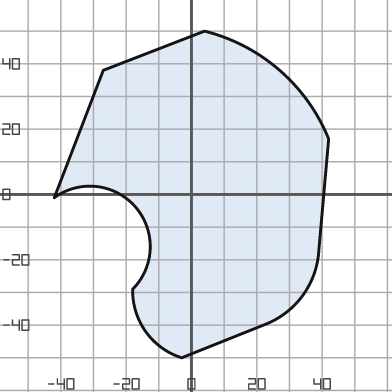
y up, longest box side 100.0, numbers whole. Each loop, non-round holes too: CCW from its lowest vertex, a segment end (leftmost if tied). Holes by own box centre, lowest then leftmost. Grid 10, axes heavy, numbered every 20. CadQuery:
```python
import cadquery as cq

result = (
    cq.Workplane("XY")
    .moveTo(-3.0, -50.0)
    .lineTo(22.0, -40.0)
    .threePointArc((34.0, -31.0), (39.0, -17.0))
    .lineTo(42.0, 17.0)
    .threePointArc((27.0, 38.0), (4.0, 50.0))
    .lineTo(-27.0, 38.0)
    .lineTo(-42.0, -1.0)
    .threePointArc((-17.0, -4.0), (-18.0, -29.0))
    .threePointArc((-14.0, -42.0), (-3.0, -50.0))
    .close()
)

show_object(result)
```